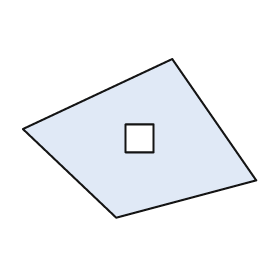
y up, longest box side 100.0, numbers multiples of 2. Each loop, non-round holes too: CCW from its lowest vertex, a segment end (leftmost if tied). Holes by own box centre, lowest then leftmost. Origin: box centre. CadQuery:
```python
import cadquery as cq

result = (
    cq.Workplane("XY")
    .moveTo(-10.0, -34.0)
    .lineTo(50.0, -18.0)
    .lineTo(14.0, 34.0)
    .lineTo(-50.0, 4.0)
    .close()
    .moveTo(-6.0, -6.0)
    .lineTo(6.0, -6.0)
    .lineTo(6.0, 6.0)
    .lineTo(-6.0, 6.0)
    .close()
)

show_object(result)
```